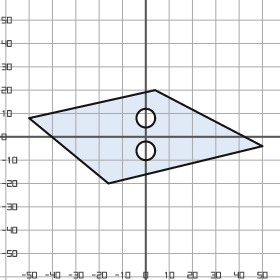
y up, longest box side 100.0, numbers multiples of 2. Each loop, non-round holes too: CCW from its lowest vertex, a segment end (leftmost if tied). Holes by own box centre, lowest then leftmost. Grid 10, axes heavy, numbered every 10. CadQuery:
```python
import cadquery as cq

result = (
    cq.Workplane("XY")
    .moveTo(-16.0, -20.0)
    .lineTo(50.0, -4.0)
    .lineTo(4.0, 20.0)
    .lineTo(-50.0, 8.0)
    .close()
    .moveTo(0.0, -6.0)
    .circle(4.0)
    .moveTo(0.0, 8.0)
    .circle(4.0)
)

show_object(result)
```